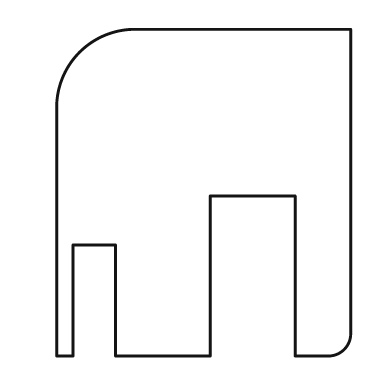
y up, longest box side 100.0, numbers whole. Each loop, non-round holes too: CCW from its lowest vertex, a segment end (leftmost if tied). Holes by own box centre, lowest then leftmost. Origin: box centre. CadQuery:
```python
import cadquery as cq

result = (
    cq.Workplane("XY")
    .moveTo(-45.0, -50.0)
    .lineTo(-40.0, -50.0)
    .lineTo(-40.0, -16.0)
    .lineTo(-27.0, -16.0)
    .lineTo(-27.0, -50.0)
    .lineTo(2.0, -50.0)
    .lineTo(2.0, -1.0)
    .lineTo(28.0, -1.0)
    .lineTo(28.0, -50.0)
    .lineTo(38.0, -50.0)
    .threePointArc((43.0, -48.0), (45.0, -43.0))
    .lineTo(45.0, 50.0)
    .lineTo(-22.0, 50.0)
    .threePointArc((-38.0, 43.0), (-45.0, 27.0))
    .close()
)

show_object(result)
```